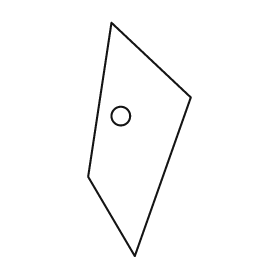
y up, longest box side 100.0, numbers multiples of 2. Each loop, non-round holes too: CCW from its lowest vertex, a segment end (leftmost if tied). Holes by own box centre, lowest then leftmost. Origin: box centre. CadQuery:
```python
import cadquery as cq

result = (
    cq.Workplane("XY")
    .moveTo(-2.0, -50.0)
    .lineTo(22.0, 18.0)
    .lineTo(-12.0, 50.0)
    .lineTo(-22.0, -16.0)
    .close()
    .moveTo(-8.0, 10.0)
    .circle(4.0)
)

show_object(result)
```